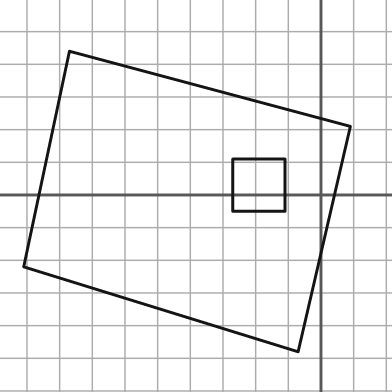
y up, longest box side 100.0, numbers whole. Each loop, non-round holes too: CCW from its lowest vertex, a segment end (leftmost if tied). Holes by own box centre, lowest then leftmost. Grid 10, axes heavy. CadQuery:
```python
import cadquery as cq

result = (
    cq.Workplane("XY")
    .moveTo(-7.0, -48.0)
    .lineTo(9.0, 21.0)
    .lineTo(-77.0, 44.0)
    .lineTo(-91.0, -22.0)
    .close()
    .moveTo(-27.0, -5.0)
    .lineTo(-11.0, -5.0)
    .lineTo(-11.0, 11.0)
    .lineTo(-27.0, 11.0)
    .close()
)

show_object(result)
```